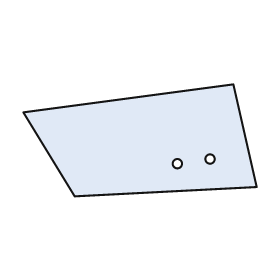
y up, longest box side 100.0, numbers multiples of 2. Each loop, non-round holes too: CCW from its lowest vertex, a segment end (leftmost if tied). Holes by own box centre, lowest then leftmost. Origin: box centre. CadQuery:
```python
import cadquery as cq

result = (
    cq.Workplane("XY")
    .moveTo(-28.0, -24.0)
    .lineTo(50.0, -20.0)
    .lineTo(40.0, 24.0)
    .lineTo(-50.0, 12.0)
    .close()
    .moveTo(16.0, -10.0)
    .circle(2.0)
    .moveTo(30.0, -8.0)
    .circle(2.0)
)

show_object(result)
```